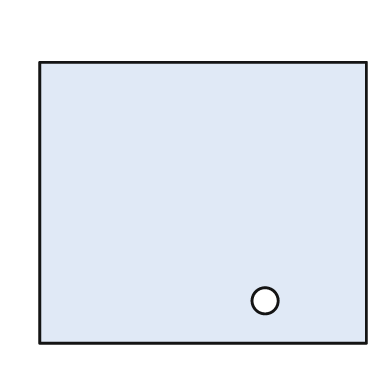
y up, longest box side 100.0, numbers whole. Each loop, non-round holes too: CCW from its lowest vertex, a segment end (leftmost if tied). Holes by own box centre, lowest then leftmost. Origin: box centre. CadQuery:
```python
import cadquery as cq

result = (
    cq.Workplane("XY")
    .moveTo(-50.0, -43.0)
    .lineTo(50.0, -43.0)
    .lineTo(50.0, 43.0)
    .lineTo(-50.0, 43.0)
    .close()
    .moveTo(19.0, -30.0)
    .circle(4.0)
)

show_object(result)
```